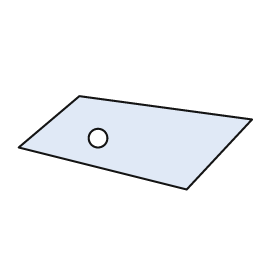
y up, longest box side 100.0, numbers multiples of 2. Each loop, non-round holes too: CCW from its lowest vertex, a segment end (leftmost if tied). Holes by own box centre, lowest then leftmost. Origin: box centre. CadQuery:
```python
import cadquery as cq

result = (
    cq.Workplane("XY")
    .moveTo(22.0, -20.0)
    .lineTo(50.0, 10.0)
    .lineTo(-24.0, 20.0)
    .lineTo(-50.0, -2.0)
    .close()
    .moveTo(-16.0, 2.0)
    .circle(4.0)
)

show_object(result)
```